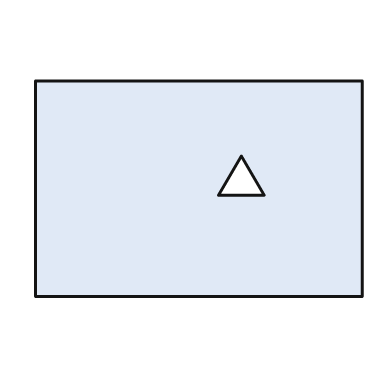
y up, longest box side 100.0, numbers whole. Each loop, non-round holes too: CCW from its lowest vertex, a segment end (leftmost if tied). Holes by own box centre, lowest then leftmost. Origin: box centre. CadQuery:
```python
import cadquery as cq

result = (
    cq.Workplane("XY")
    .moveTo(-50.0, -33.0)
    .lineTo(50.0, -33.0)
    .lineTo(50.0, 33.0)
    .lineTo(-50.0, 33.0)
    .close()
    .moveTo(6.0, -2.0)
    .lineTo(20.0, -2.0)
    .lineTo(13.0, 10.0)
    .close()
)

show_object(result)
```